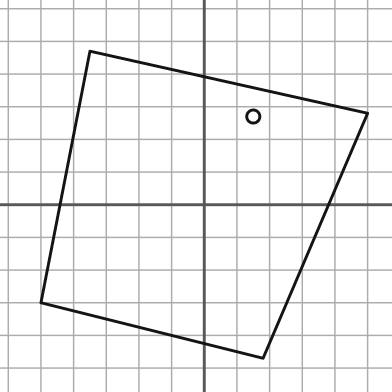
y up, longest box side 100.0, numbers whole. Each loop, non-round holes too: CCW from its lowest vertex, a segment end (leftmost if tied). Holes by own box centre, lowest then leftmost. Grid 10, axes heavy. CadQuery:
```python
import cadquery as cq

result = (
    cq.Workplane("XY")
    .moveTo(18.0, -47.0)
    .lineTo(50.0, 28.0)
    .lineTo(-35.0, 47.0)
    .lineTo(-50.0, -30.0)
    .close()
    .moveTo(15.0, 27.0)
    .circle(2.0)
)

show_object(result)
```